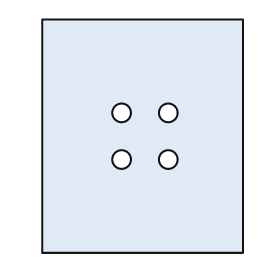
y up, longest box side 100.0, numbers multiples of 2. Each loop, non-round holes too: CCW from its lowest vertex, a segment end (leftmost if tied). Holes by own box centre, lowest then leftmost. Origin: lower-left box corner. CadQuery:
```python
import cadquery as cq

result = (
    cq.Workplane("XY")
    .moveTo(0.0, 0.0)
    .lineTo(86.0, 0.0)
    .lineTo(86.0, 100.0)
    .lineTo(0.0, 100.0)
    .close()
    .moveTo(34.0, 40.0)
    .circle(4.0)
    .moveTo(54.0, 40.0)
    .circle(4.0)
    .moveTo(34.0, 60.0)
    .circle(4.0)
    .moveTo(54.0, 60.0)
    .circle(4.0)
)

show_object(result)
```